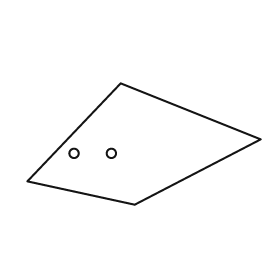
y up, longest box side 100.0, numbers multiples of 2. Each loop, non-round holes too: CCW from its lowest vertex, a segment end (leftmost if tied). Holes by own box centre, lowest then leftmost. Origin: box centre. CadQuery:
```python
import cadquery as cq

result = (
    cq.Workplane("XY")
    .moveTo(-4.0, -26.0)
    .lineTo(50.0, 2.0)
    .lineTo(-10.0, 26.0)
    .lineTo(-50.0, -16.0)
    .close()
    .moveTo(-30.0, -4.0)
    .circle(2.0)
    .moveTo(-14.0, -4.0)
    .circle(2.0)
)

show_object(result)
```